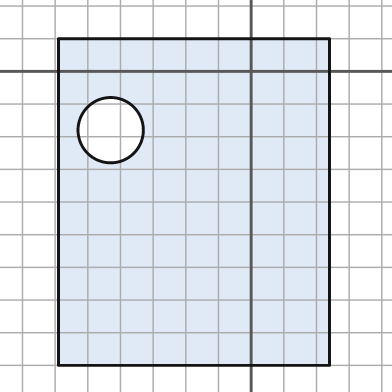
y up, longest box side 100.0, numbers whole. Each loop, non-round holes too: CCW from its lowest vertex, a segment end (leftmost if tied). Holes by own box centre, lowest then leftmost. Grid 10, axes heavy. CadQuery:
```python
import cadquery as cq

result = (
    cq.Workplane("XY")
    .moveTo(-59.0, -90.0)
    .lineTo(24.0, -90.0)
    .lineTo(24.0, 10.0)
    .lineTo(-59.0, 10.0)
    .close()
    .moveTo(-43.0, -18.0)
    .circle(10.0)
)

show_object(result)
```